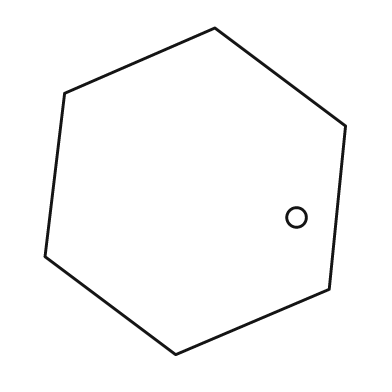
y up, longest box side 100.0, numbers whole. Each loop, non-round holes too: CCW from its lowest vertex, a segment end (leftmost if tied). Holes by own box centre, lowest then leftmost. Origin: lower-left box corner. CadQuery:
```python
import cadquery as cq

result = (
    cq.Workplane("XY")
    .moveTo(40.0, 0.0)
    .lineTo(87.0, 20.0)
    .lineTo(92.0, 70.0)
    .lineTo(52.0, 100.0)
    .lineTo(6.0, 80.0)
    .lineTo(0.0, 30.0)
    .close()
    .moveTo(77.0, 42.0)
    .circle(3.0)
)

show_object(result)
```